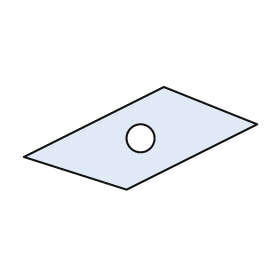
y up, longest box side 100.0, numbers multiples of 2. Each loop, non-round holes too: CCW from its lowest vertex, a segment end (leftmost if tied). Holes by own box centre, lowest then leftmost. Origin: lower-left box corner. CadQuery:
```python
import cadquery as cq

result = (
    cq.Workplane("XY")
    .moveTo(44.0, 0.0)
    .lineTo(100.0, 28.0)
    .lineTo(60.0, 44.0)
    .lineTo(0.0, 14.0)
    .close()
    .moveTo(50.0, 22.0)
    .circle(6.0)
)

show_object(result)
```